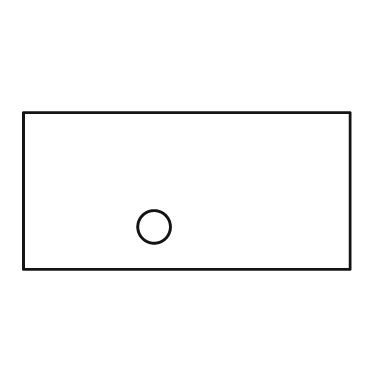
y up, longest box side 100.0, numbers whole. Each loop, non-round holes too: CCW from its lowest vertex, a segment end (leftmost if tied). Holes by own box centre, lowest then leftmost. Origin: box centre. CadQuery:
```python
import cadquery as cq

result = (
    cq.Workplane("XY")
    .moveTo(-50.0, -24.0)
    .lineTo(50.0, -24.0)
    .lineTo(50.0, 24.0)
    .lineTo(-50.0, 24.0)
    .close()
    .moveTo(-10.0, -11.0)
    .circle(5.0)
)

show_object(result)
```